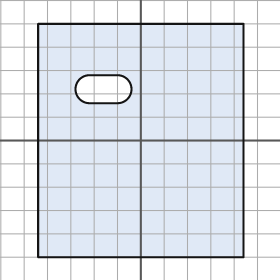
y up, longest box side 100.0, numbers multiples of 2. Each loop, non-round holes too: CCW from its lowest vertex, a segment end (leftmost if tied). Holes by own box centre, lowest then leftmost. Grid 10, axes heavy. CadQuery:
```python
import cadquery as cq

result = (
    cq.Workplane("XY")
    .moveTo(-44.0, -50.0)
    .lineTo(44.0, -50.0)
    .lineTo(44.0, 50.0)
    .lineTo(-44.0, 50.0)
    .close()
    .moveTo(-22.0, 16.0)
    .lineTo(-10.0, 16.0)
    .threePointArc((-4.0, 22.0), (-10.0, 28.0))
    .lineTo(-22.0, 28.0)
    .threePointArc((-28.0, 22.0), (-22.0, 16.0))
    .close()
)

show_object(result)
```